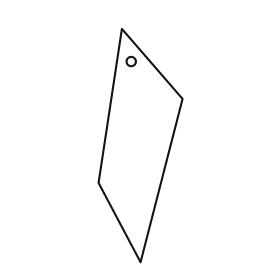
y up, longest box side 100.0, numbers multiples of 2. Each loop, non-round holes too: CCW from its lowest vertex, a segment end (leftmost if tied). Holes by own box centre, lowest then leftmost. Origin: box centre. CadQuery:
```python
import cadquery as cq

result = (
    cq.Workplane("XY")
    .moveTo(0.0, -50.0)
    .lineTo(18.0, 20.0)
    .lineTo(-8.0, 50.0)
    .lineTo(-18.0, -16.0)
    .close()
    .moveTo(-4.0, 36.0)
    .circle(2.0)
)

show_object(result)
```